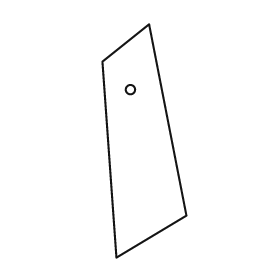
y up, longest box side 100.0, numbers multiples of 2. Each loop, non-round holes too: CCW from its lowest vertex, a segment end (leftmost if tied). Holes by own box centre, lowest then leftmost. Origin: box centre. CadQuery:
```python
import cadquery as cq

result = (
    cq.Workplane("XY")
    .moveTo(-12.0, -50.0)
    .lineTo(18.0, -32.0)
    .lineTo(2.0, 50.0)
    .lineTo(-18.0, 34.0)
    .close()
    .moveTo(-6.0, 22.0)
    .circle(2.0)
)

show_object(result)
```